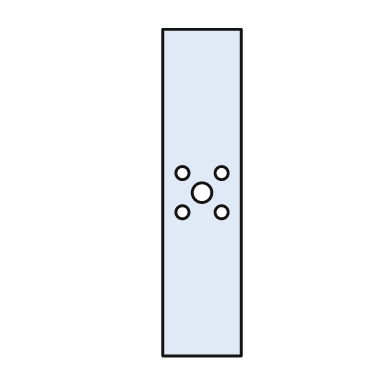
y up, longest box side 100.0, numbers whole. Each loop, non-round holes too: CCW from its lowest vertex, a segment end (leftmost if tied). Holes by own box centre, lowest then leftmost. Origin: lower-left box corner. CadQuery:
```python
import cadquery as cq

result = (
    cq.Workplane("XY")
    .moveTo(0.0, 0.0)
    .lineTo(24.0, 0.0)
    .lineTo(24.0, 100.0)
    .lineTo(0.0, 100.0)
    .close()
    .moveTo(6.0, 44.0)
    .circle(2.0)
    .moveTo(18.0, 44.0)
    .circle(2.0)
    .moveTo(12.0, 50.0)
    .circle(3.0)
    .moveTo(6.0, 56.0)
    .circle(2.0)
    .moveTo(18.0, 56.0)
    .circle(2.0)
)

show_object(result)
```